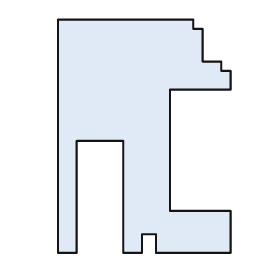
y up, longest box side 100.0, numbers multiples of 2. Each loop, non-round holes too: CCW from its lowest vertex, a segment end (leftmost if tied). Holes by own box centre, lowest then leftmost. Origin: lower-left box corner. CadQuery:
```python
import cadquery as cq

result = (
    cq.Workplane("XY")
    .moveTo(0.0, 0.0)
    .lineTo(8.0, 0.0)
    .lineTo(8.0, 48.0)
    .lineTo(28.0, 48.0)
    .lineTo(28.0, 0.0)
    .lineTo(36.0, 0.0)
    .lineTo(36.0, 8.0)
    .lineTo(42.0, 8.0)
    .lineTo(42.0, 0.0)
    .lineTo(74.0, 0.0)
    .lineTo(74.0, 18.0)
    .lineTo(48.0, 18.0)
    .lineTo(48.0, 70.0)
    .lineTo(74.0, 70.0)
    .lineTo(74.0, 78.0)
    .lineTo(70.0, 78.0)
    .lineTo(70.0, 82.0)
    .lineTo(62.0, 82.0)
    .lineTo(62.0, 96.0)
    .lineTo(58.0, 96.0)
    .lineTo(58.0, 100.0)
    .lineTo(0.0, 100.0)
    .close()
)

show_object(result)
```